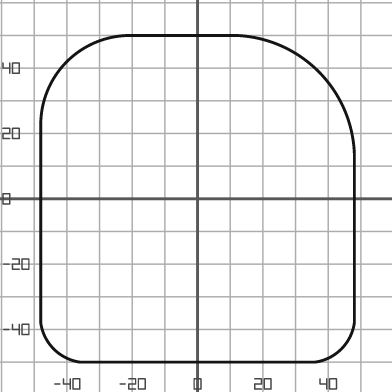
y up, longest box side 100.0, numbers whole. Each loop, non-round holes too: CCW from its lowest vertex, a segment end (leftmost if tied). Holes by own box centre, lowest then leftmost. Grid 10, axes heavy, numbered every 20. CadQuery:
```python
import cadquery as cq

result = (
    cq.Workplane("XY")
    .moveTo(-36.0, -50.0)
    .lineTo(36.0, -50.0)
    .threePointArc((44.0, -46.0), (48.0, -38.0))
    .lineTo(48.0, 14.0)
    .threePointArc((37.0, 39.0), (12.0, 50.0))
    .lineTo(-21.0, 50.0)
    .threePointArc((-40.0, 42.0), (-48.0, 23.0))
    .lineTo(-48.0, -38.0)
    .threePointArc((-44.0, -46.0), (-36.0, -50.0))
    .close()
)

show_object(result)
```